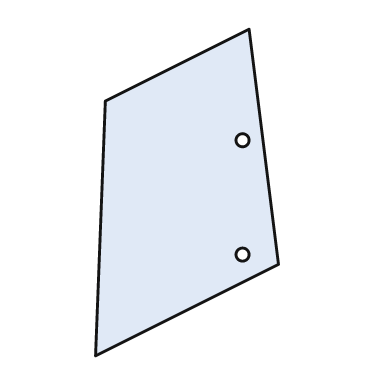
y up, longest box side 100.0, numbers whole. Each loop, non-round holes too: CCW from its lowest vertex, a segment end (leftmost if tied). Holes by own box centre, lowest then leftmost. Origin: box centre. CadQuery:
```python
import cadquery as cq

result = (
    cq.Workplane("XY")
    .moveTo(-28.0, -50.0)
    .lineTo(28.0, -22.0)
    .lineTo(19.0, 50.0)
    .lineTo(-25.0, 28.0)
    .close()
    .moveTo(17.0, -19.0)
    .circle(2.0)
    .moveTo(17.0, 16.0)
    .circle(2.0)
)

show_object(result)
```